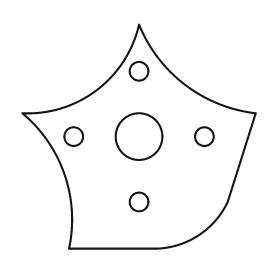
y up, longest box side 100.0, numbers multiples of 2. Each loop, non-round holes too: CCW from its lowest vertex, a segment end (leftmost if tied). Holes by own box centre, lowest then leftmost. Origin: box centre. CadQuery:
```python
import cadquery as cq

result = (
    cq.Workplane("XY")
    .moveTo(-30.0, -48.0)
    .lineTo(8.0, -48.0)
    .threePointArc((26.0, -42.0), (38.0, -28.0))
    .lineTo(50.0, 10.0)
    .threePointArc((20.0, 22.0), (0.0, 48.0))
    .threePointArc((-18.0, 20.0), (-50.0, 10.0))
    .threePointArc((-32.0, -16.0), (-30.0, -48.0))
    .close()
    .moveTo(0.0, -28.0)
    .circle(4.0)
    .moveTo(-28.0, 0.0)
    .circle(4.0)
    .moveTo(0.0, 0.0)
    .circle(10.0)
    .moveTo(28.0, 0.0)
    .circle(4.0)
    .moveTo(0.0, 28.0)
    .circle(4.0)
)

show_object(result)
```